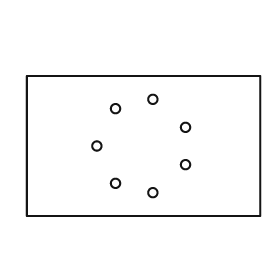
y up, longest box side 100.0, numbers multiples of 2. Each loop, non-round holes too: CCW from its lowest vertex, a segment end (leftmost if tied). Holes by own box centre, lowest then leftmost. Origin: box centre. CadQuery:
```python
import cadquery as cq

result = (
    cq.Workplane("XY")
    .moveTo(-50.0, -30.0)
    .lineTo(50.0, -30.0)
    .lineTo(50.0, 30.0)
    .lineTo(-50.0, 30.0)
    .close()
    .moveTo(4.0, -20.0)
    .circle(2.0)
    .moveTo(-12.0, -16.0)
    .circle(2.0)
    .moveTo(18.0, -8.0)
    .circle(2.0)
    .moveTo(-20.0, 0.0)
    .circle(2.0)
    .moveTo(18.0, 8.0)
    .circle(2.0)
    .moveTo(-12.0, 16.0)
    .circle(2.0)
    .moveTo(4.0, 20.0)
    .circle(2.0)
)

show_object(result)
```